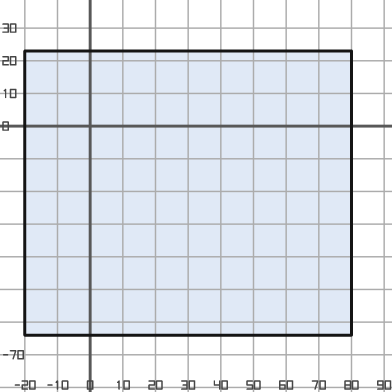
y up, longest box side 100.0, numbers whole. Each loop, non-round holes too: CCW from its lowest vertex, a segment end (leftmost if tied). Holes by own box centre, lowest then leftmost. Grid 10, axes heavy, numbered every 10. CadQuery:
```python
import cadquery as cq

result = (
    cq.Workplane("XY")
    .moveTo(-20.0, -64.0)
    .lineTo(80.0, -64.0)
    .lineTo(80.0, 23.0)
    .lineTo(-20.0, 23.0)
    .close()
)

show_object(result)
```